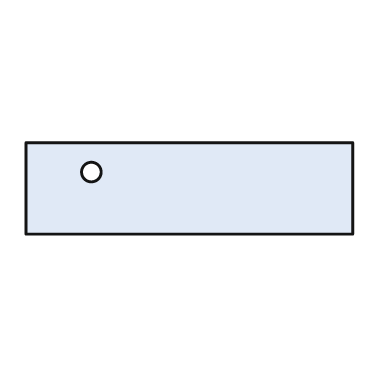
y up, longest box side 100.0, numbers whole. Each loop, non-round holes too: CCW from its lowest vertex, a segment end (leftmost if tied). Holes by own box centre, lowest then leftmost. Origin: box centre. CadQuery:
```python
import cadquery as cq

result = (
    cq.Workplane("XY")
    .moveTo(-50.0, -14.0)
    .lineTo(50.0, -14.0)
    .lineTo(50.0, 14.0)
    .lineTo(-50.0, 14.0)
    .close()
    .moveTo(-30.0, 5.0)
    .circle(3.0)
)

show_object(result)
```